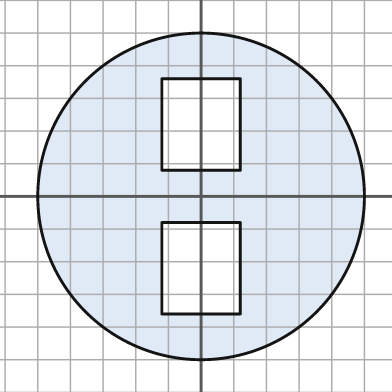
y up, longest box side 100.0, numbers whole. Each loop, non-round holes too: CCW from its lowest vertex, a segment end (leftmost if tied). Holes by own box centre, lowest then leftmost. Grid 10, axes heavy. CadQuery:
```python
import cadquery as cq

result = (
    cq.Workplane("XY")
    .moveTo(0.0, 0.0)
    .circle(50.0)
    .moveTo(-12.0, -36.0)
    .lineTo(12.0, -36.0)
    .lineTo(12.0, -8.0)
    .lineTo(-12.0, -8.0)
    .close()
    .moveTo(-12.0, 8.0)
    .lineTo(12.0, 8.0)
    .lineTo(12.0, 36.0)
    .lineTo(-12.0, 36.0)
    .close()
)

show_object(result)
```